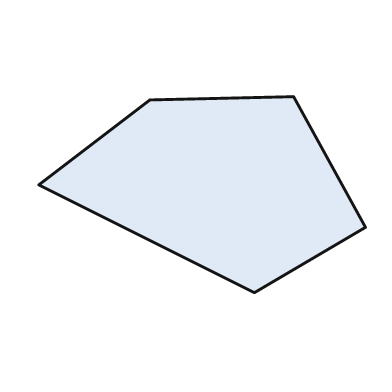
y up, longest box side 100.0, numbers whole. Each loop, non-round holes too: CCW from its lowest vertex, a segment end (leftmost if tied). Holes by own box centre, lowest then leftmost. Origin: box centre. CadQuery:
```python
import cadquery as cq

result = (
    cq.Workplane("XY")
    .moveTo(16.0, -30.0)
    .lineTo(50.0, -10.0)
    .lineTo(28.0, 30.0)
    .lineTo(-16.0, 29.0)
    .lineTo(-50.0, 3.0)
    .close()
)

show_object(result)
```